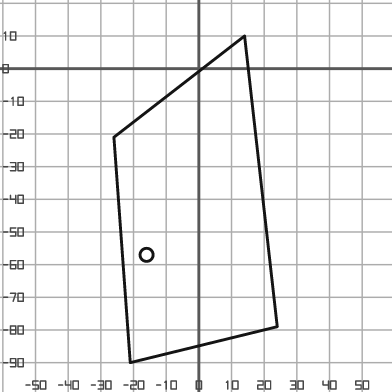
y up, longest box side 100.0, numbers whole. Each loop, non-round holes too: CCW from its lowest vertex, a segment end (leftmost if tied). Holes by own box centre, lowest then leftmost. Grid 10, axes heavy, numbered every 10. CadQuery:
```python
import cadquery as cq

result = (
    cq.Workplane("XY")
    .moveTo(-21.0, -90.0)
    .lineTo(24.0, -79.0)
    .lineTo(14.0, 10.0)
    .lineTo(-26.0, -21.0)
    .close()
    .moveTo(-16.0, -57.0)
    .circle(2.0)
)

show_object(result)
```